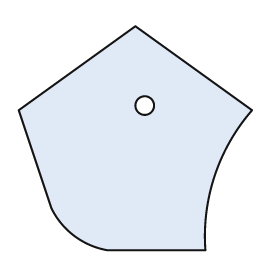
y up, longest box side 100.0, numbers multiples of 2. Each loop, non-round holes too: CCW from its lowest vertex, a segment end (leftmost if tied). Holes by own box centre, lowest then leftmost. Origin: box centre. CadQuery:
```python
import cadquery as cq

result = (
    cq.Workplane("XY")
    .moveTo(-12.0, -48.0)
    .lineTo(30.0, -48.0)
    .threePointArc((34.0, -16.0), (50.0, 12.0))
    .lineTo(0.0, 48.0)
    .lineTo(-50.0, 12.0)
    .lineTo(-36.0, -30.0)
    .threePointArc((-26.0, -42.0), (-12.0, -48.0))
    .close()
    .moveTo(4.0, 14.0)
    .circle(4.0)
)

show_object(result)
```